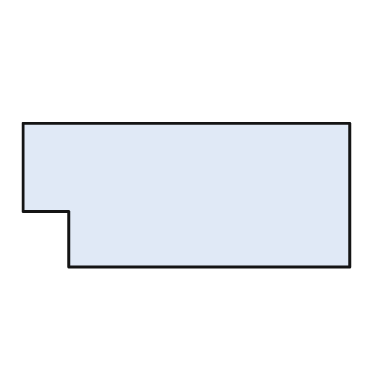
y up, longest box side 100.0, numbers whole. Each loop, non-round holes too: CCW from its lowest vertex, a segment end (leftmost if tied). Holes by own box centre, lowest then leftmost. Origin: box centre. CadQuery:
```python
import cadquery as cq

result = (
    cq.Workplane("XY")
    .moveTo(-36.0, -22.0)
    .lineTo(50.0, -22.0)
    .lineTo(50.0, 22.0)
    .lineTo(-50.0, 22.0)
    .lineTo(-50.0, -5.0)
    .lineTo(-36.0, -5.0)
    .close()
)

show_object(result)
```